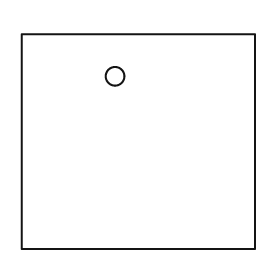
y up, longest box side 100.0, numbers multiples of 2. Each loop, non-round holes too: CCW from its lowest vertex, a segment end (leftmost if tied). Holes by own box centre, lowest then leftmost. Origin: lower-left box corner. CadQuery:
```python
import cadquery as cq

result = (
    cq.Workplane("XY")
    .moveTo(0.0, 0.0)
    .lineTo(100.0, 0.0)
    .lineTo(100.0, 92.0)
    .lineTo(0.0, 92.0)
    .close()
    .moveTo(40.0, 74.0)
    .circle(4.0)
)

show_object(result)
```